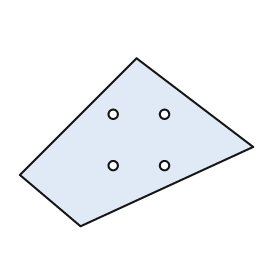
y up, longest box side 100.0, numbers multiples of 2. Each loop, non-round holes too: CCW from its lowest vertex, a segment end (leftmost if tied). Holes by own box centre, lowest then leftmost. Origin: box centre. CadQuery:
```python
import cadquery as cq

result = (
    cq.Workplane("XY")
    .moveTo(-24.0, -36.0)
    .lineTo(50.0, -2.0)
    .lineTo(0.0, 36.0)
    .lineTo(-50.0, -14.0)
    .close()
    .moveTo(-10.0, -10.0)
    .circle(2.0)
    .moveTo(12.0, -10.0)
    .circle(2.0)
    .moveTo(-10.0, 12.0)
    .circle(2.0)
    .moveTo(12.0, 12.0)
    .circle(2.0)
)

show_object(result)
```